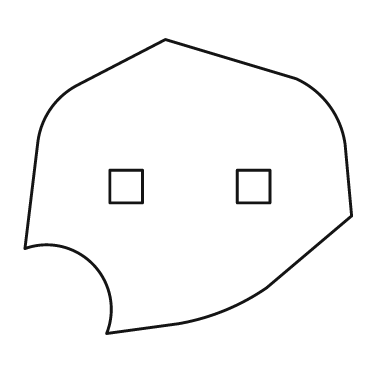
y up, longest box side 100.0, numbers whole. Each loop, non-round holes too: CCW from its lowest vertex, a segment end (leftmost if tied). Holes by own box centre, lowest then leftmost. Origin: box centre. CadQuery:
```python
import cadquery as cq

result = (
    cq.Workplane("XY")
    .moveTo(-25.0, -45.0)
    .lineTo(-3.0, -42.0)
    .threePointArc((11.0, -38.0), (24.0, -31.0))
    .lineTo(50.0, -9.0)
    .lineTo(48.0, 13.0)
    .threePointArc((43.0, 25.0), (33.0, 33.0))
    .lineTo(-7.0, 45.0)
    .lineTo(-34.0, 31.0)
    .threePointArc((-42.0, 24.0), (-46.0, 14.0))
    .lineTo(-50.0, -19.0)
    .threePointArc((-29.0, -24.0), (-25.0, -45.0))
    .close()
    .moveTo(-24.0, -5.0)
    .lineTo(-14.0, -5.0)
    .lineTo(-14.0, 5.0)
    .lineTo(-24.0, 5.0)
    .close()
    .moveTo(15.0, -5.0)
    .lineTo(25.0, -5.0)
    .lineTo(25.0, 5.0)
    .lineTo(15.0, 5.0)
    .close()
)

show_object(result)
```